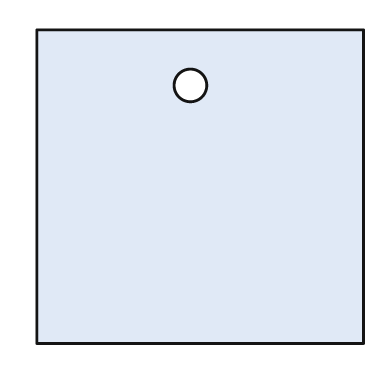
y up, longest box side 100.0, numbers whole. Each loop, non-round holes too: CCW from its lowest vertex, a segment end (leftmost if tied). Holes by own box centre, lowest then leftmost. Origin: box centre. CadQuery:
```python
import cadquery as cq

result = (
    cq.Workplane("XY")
    .moveTo(-50.0, -48.0)
    .lineTo(50.0, -48.0)
    .lineTo(50.0, 48.0)
    .lineTo(-50.0, 48.0)
    .close()
    .moveTo(-3.0, 31.0)
    .circle(5.0)
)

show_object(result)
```